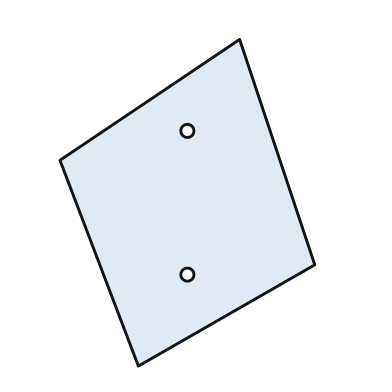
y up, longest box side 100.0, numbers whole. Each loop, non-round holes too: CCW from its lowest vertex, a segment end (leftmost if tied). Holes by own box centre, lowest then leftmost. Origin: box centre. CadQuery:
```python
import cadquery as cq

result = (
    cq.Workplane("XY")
    .moveTo(-15.0, -50.0)
    .lineTo(39.0, -19.0)
    .lineTo(16.0, 50.0)
    .lineTo(-39.0, 13.0)
    .close()
    .moveTo(0.0, -22.0)
    .circle(2.0)
    .moveTo(0.0, 22.0)
    .circle(2.0)
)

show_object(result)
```